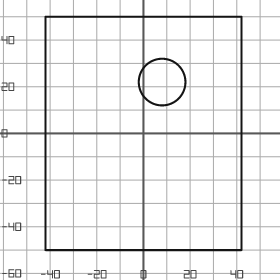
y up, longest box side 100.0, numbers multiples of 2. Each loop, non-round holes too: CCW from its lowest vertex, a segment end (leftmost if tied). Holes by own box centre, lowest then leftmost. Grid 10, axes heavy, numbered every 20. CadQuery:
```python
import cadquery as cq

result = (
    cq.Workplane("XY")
    .moveTo(-42.0, -50.0)
    .lineTo(42.0, -50.0)
    .lineTo(42.0, 50.0)
    .lineTo(-42.0, 50.0)
    .close()
    .moveTo(8.0, 22.0)
    .circle(10.0)
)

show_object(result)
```